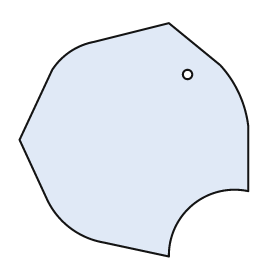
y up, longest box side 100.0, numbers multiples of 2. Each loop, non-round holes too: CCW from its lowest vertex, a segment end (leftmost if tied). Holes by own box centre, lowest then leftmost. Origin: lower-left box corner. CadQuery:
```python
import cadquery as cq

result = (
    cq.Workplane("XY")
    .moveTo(64.0, 0.0)
    .threePointArc((74.0, 22.0), (98.0, 28.0))
    .lineTo(98.0, 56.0)
    .threePointArc((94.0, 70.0), (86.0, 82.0))
    .lineTo(64.0, 100.0)
    .lineTo(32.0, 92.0)
    .threePointArc((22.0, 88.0), (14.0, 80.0))
    .lineTo(0.0, 50.0)
    .lineTo(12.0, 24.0)
    .threePointArc((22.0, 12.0), (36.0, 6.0))
    .close()
    .moveTo(72.0, 78.0)
    .circle(2.0)
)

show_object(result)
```